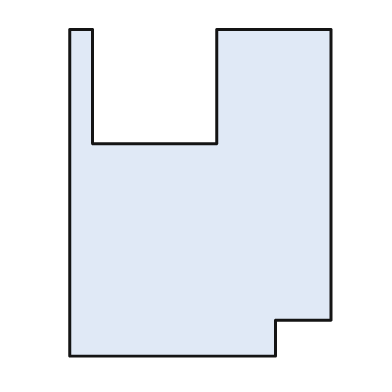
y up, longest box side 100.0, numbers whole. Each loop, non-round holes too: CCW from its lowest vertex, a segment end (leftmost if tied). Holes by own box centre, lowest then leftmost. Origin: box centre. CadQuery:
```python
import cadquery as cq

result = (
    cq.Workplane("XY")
    .moveTo(-40.0, -50.0)
    .lineTo(23.0, -50.0)
    .lineTo(23.0, -39.0)
    .lineTo(40.0, -39.0)
    .lineTo(40.0, 50.0)
    .lineTo(5.0, 50.0)
    .lineTo(5.0, 15.0)
    .lineTo(-33.0, 15.0)
    .lineTo(-33.0, 50.0)
    .lineTo(-40.0, 50.0)
    .close()
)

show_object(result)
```